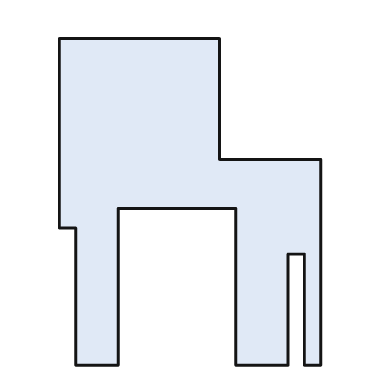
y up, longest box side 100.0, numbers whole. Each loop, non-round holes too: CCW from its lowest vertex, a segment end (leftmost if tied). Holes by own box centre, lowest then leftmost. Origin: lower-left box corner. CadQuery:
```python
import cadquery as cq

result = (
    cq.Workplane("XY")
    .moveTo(5.0, 0.0)
    .lineTo(18.0, 0.0)
    .lineTo(18.0, 48.0)
    .lineTo(54.0, 48.0)
    .lineTo(54.0, 0.0)
    .lineTo(70.0, 0.0)
    .lineTo(70.0, 34.0)
    .lineTo(75.0, 34.0)
    .lineTo(75.0, 0.0)
    .lineTo(80.0, 0.0)
    .lineTo(80.0, 63.0)
    .lineTo(49.0, 63.0)
    .lineTo(49.0, 100.0)
    .lineTo(0.0, 100.0)
    .lineTo(0.0, 42.0)
    .lineTo(5.0, 42.0)
    .close()
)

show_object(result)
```